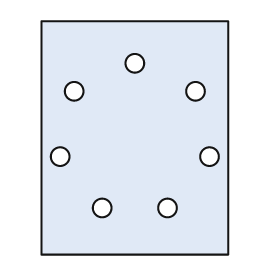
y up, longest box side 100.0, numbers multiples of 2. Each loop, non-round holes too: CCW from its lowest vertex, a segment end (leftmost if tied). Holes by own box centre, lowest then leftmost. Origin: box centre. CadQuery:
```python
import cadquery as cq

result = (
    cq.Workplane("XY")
    .moveTo(-40.0, -50.0)
    .lineTo(40.0, -50.0)
    .lineTo(40.0, 50.0)
    .lineTo(-40.0, 50.0)
    .close()
    .moveTo(-14.0, -30.0)
    .circle(4.0)
    .moveTo(14.0, -30.0)
    .circle(4.0)
    .moveTo(-32.0, -8.0)
    .circle(4.0)
    .moveTo(32.0, -8.0)
    .circle(4.0)
    .moveTo(-26.0, 20.0)
    .circle(4.0)
    .moveTo(26.0, 20.0)
    .circle(4.0)
    .moveTo(0.0, 32.0)
    .circle(4.0)
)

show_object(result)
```